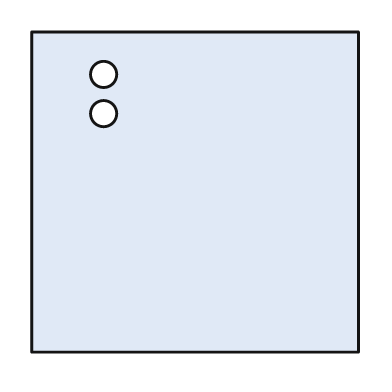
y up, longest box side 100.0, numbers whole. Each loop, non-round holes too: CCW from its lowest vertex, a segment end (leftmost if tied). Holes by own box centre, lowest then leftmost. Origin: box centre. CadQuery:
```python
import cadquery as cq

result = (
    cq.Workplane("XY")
    .moveTo(-50.0, -49.0)
    .lineTo(50.0, -49.0)
    .lineTo(50.0, 49.0)
    .lineTo(-50.0, 49.0)
    .close()
    .moveTo(-28.0, 24.0)
    .circle(4.0)
    .moveTo(-28.0, 36.0)
    .circle(4.0)
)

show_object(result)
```